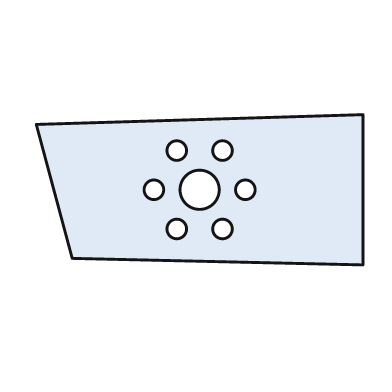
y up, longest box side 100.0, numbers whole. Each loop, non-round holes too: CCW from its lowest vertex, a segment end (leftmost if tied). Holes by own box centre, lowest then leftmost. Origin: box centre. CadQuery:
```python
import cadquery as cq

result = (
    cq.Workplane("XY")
    .moveTo(50.0, -23.0)
    .lineTo(50.0, 23.0)
    .lineTo(-50.0, 20.0)
    .lineTo(-39.0, -21.0)
    .close()
    .moveTo(-7.0, -12.0)
    .circle(3.0)
    .moveTo(7.0, -12.0)
    .circle(3.0)
    .moveTo(-14.0, 0.0)
    .circle(3.0)
    .moveTo(0.0, 0.0)
    .circle(6.0)
    .moveTo(14.0, 0.0)
    .circle(3.0)
    .moveTo(-7.0, 12.0)
    .circle(3.0)
    .moveTo(7.0, 12.0)
    .circle(3.0)
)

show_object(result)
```